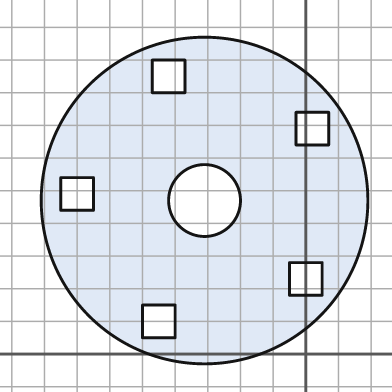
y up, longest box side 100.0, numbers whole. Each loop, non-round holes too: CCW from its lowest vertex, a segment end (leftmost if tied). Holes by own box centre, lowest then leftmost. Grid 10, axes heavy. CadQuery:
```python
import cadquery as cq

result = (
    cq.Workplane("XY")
    .moveTo(-31.0, 47.0)
    .circle(50.0)
    .moveTo(-50.0, 5.0)
    .lineTo(-40.0, 5.0)
    .lineTo(-40.0, 15.0)
    .lineTo(-50.0, 15.0)
    .close()
    .moveTo(-5.0, 18.0)
    .lineTo(5.0, 18.0)
    .lineTo(5.0, 28.0)
    .lineTo(-5.0, 28.0)
    .close()
    .moveTo(-31.0, 47.0)
    .circle(11.0)
    .moveTo(-75.0, 44.0)
    .lineTo(-65.0, 44.0)
    .lineTo(-65.0, 54.0)
    .lineTo(-75.0, 54.0)
    .close()
    .moveTo(-3.0, 64.0)
    .lineTo(7.0, 64.0)
    .lineTo(7.0, 74.0)
    .lineTo(-3.0, 74.0)
    .close()
    .moveTo(-47.0, 80.0)
    .lineTo(-37.0, 80.0)
    .lineTo(-37.0, 90.0)
    .lineTo(-47.0, 90.0)
    .close()
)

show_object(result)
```